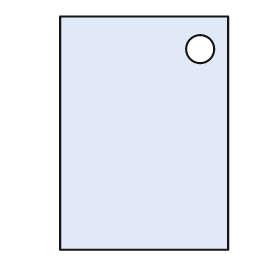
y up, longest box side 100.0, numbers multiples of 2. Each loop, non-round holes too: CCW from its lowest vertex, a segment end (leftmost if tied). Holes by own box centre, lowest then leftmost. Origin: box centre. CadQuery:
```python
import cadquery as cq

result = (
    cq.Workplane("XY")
    .moveTo(-36.0, -50.0)
    .lineTo(36.0, -50.0)
    .lineTo(36.0, 50.0)
    .lineTo(-36.0, 50.0)
    .close()
    .moveTo(24.0, 36.0)
    .circle(6.0)
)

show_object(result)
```